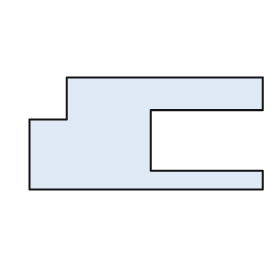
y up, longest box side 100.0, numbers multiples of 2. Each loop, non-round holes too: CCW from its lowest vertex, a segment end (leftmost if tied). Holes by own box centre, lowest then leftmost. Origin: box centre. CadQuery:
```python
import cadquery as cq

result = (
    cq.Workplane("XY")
    .moveTo(-50.0, -24.0)
    .lineTo(50.0, -24.0)
    .lineTo(50.0, -16.0)
    .lineTo(2.0, -16.0)
    .lineTo(2.0, 10.0)
    .lineTo(50.0, 10.0)
    .lineTo(50.0, 24.0)
    .lineTo(-34.0, 24.0)
    .lineTo(-34.0, 6.0)
    .lineTo(-50.0, 6.0)
    .close()
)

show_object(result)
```